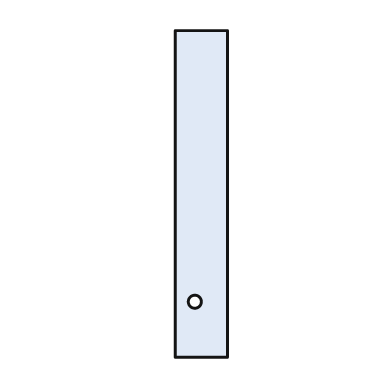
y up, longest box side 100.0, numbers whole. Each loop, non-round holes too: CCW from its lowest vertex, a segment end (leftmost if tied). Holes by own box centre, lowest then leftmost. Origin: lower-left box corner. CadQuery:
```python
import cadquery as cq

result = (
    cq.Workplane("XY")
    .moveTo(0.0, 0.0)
    .lineTo(16.0, 0.0)
    .lineTo(16.0, 100.0)
    .lineTo(0.0, 100.0)
    .close()
    .moveTo(6.0, 17.0)
    .circle(2.0)
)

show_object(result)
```